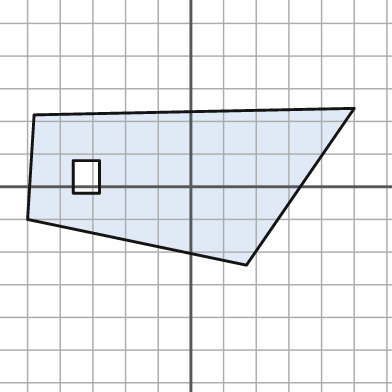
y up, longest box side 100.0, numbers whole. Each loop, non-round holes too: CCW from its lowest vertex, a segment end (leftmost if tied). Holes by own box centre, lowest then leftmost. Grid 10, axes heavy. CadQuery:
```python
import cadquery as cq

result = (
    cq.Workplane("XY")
    .moveTo(17.0, -24.0)
    .lineTo(50.0, 24.0)
    .lineTo(-48.0, 22.0)
    .lineTo(-50.0, -10.0)
    .close()
    .moveTo(-36.0, -2.0)
    .lineTo(-28.0, -2.0)
    .lineTo(-28.0, 8.0)
    .lineTo(-36.0, 8.0)
    .close()
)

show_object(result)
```